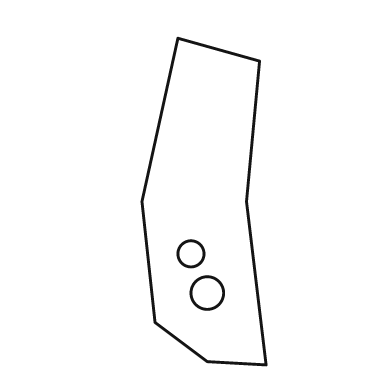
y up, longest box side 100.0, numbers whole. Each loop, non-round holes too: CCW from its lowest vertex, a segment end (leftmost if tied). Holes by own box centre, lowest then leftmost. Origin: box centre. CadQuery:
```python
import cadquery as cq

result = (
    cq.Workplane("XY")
    .moveTo(19.0, -50.0)
    .lineTo(13.0, 0.0)
    .lineTo(17.0, 43.0)
    .lineTo(-8.0, 50.0)
    .lineTo(-19.0, 0.0)
    .lineTo(-15.0, -37.0)
    .lineTo(1.0, -49.0)
    .close()
    .moveTo(1.0, -28.0)
    .circle(5.0)
    .moveTo(-4.0, -16.0)
    .circle(4.0)
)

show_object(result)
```